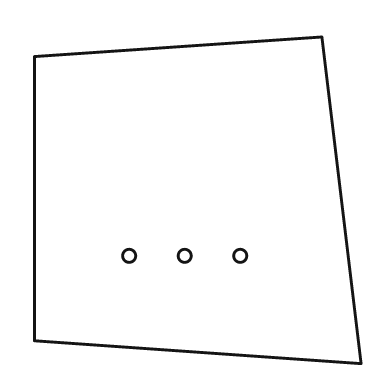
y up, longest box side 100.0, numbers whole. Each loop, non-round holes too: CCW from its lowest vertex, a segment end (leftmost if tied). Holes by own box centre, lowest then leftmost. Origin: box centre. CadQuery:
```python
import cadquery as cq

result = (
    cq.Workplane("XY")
    .moveTo(50.0, -50.0)
    .lineTo(38.0, 50.0)
    .lineTo(-50.0, 44.0)
    .lineTo(-50.0, -43.0)
    .close()
    .moveTo(-21.0, -17.0)
    .circle(2.0)
    .moveTo(-4.0, -17.0)
    .circle(2.0)
    .moveTo(13.0, -17.0)
    .circle(2.0)
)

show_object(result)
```